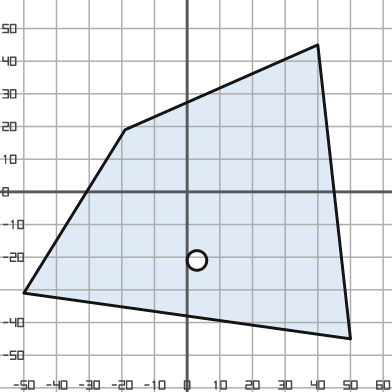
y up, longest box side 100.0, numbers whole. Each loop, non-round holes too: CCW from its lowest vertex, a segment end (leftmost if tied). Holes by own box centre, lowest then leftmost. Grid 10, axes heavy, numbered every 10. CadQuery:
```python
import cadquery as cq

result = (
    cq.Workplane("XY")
    .moveTo(50.0, -45.0)
    .lineTo(40.0, 45.0)
    .lineTo(-19.0, 19.0)
    .lineTo(-50.0, -31.0)
    .close()
    .moveTo(3.0, -21.0)
    .circle(3.0)
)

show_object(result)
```